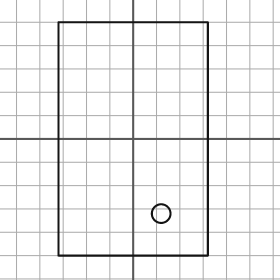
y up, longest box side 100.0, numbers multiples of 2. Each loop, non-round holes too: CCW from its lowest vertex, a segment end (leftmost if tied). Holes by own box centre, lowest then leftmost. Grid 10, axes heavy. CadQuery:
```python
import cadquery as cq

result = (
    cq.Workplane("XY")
    .moveTo(-32.0, -50.0)
    .lineTo(32.0, -50.0)
    .lineTo(32.0, 50.0)
    .lineTo(-32.0, 50.0)
    .close()
    .moveTo(12.0, -32.0)
    .circle(4.0)
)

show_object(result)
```